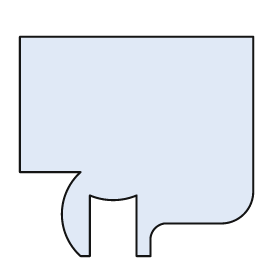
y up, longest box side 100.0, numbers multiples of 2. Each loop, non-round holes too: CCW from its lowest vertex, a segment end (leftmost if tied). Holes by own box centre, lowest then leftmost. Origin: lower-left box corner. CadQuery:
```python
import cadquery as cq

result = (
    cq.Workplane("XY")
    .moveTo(26.0, 0.0)
    .lineTo(30.0, 0.0)
    .lineTo(30.0, 26.0)
    .threePointArc((40.0, 24.0), (50.0, 26.0))
    .lineTo(50.0, 0.0)
    .lineTo(56.0, 0.0)
    .lineTo(56.0, 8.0)
    .threePointArc((58.0, 12.0), (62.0, 14.0))
    .lineTo(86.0, 14.0)
    .threePointArc((96.0, 18.0), (100.0, 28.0))
    .lineTo(100.0, 94.0)
    .lineTo(0.0, 94.0)
    .lineTo(0.0, 36.0)
    .lineTo(26.0, 36.0)
    .threePointArc((18.0, 18.0), (26.0, 0.0))
    .close()
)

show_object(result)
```